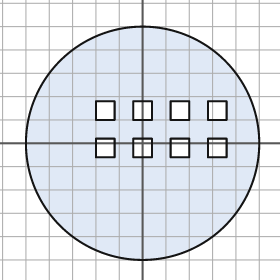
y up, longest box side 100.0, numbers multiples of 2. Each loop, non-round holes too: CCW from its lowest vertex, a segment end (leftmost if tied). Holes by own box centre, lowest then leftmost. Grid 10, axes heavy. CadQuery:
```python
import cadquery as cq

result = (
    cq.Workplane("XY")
    .moveTo(0.0, 0.0)
    .circle(50.0)
    .moveTo(-20.0, -6.0)
    .lineTo(-12.0, -6.0)
    .lineTo(-12.0, 2.0)
    .lineTo(-20.0, 2.0)
    .close()
    .moveTo(-4.0, -6.0)
    .lineTo(4.0, -6.0)
    .lineTo(4.0, 2.0)
    .lineTo(-4.0, 2.0)
    .close()
    .moveTo(12.0, -6.0)
    .lineTo(20.0, -6.0)
    .lineTo(20.0, 2.0)
    .lineTo(12.0, 2.0)
    .close()
    .moveTo(28.0, -6.0)
    .lineTo(36.0, -6.0)
    .lineTo(36.0, 2.0)
    .lineTo(28.0, 2.0)
    .close()
    .moveTo(-20.0, 10.0)
    .lineTo(-12.0, 10.0)
    .lineTo(-12.0, 18.0)
    .lineTo(-20.0, 18.0)
    .close()
    .moveTo(-4.0, 10.0)
    .lineTo(4.0, 10.0)
    .lineTo(4.0, 18.0)
    .lineTo(-4.0, 18.0)
    .close()
    .moveTo(12.0, 10.0)
    .lineTo(20.0, 10.0)
    .lineTo(20.0, 18.0)
    .lineTo(12.0, 18.0)
    .close()
    .moveTo(28.0, 10.0)
    .lineTo(36.0, 10.0)
    .lineTo(36.0, 18.0)
    .lineTo(28.0, 18.0)
    .close()
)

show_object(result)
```